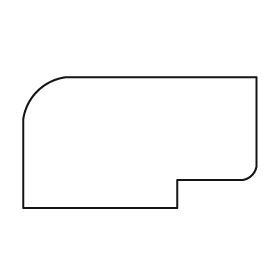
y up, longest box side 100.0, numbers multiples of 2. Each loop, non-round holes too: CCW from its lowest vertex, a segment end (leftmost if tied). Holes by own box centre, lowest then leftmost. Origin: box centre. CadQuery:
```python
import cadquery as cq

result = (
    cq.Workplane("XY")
    .moveTo(-50.0, -28.0)
    .lineTo(16.0, -28.0)
    .lineTo(16.0, -16.0)
    .lineTo(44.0, -16.0)
    .threePointArc((48.0, -14.0), (50.0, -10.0))
    .lineTo(50.0, 28.0)
    .lineTo(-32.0, 28.0)
    .threePointArc((-44.0, 22.0), (-50.0, 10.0))
    .close()
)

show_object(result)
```